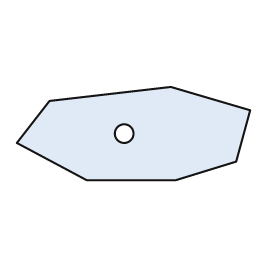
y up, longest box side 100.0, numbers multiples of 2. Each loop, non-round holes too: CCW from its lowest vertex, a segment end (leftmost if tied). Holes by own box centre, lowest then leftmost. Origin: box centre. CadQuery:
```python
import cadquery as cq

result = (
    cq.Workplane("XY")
    .moveTo(-20.0, -20.0)
    .lineTo(18.0, -20.0)
    .lineTo(44.0, -12.0)
    .lineTo(50.0, 10.0)
    .lineTo(16.0, 20.0)
    .lineTo(-36.0, 14.0)
    .lineTo(-50.0, -4.0)
    .close()
    .moveTo(-4.0, 0.0)
    .circle(4.0)
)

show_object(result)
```